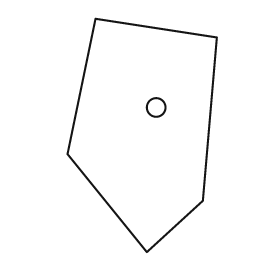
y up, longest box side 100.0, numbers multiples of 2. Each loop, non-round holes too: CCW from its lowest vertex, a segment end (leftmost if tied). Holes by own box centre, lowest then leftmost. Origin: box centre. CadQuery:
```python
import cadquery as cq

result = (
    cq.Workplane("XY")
    .moveTo(2.0, -50.0)
    .lineTo(26.0, -28.0)
    .lineTo(32.0, 42.0)
    .lineTo(-20.0, 50.0)
    .lineTo(-32.0, -8.0)
    .close()
    .moveTo(6.0, 12.0)
    .circle(4.0)
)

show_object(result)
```